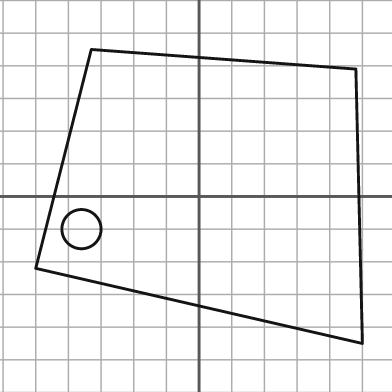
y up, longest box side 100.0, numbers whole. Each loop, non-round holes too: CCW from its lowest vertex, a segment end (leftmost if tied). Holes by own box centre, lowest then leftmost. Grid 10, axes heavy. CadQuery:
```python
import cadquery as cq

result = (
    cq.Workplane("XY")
    .moveTo(50.0, -45.0)
    .lineTo(48.0, 39.0)
    .lineTo(-33.0, 45.0)
    .lineTo(-50.0, -22.0)
    .close()
    .moveTo(-36.0, -10.0)
    .circle(6.0)
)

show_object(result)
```